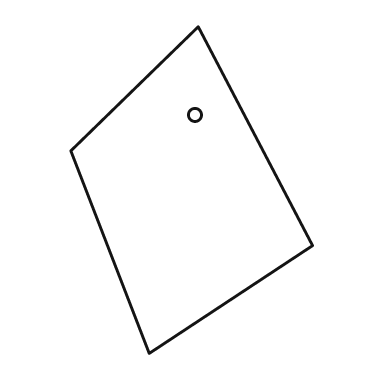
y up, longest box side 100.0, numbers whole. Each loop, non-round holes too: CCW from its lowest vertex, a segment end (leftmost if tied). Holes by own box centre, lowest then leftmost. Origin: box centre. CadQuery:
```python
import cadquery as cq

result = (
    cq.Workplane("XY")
    .moveTo(-13.0, -50.0)
    .lineTo(37.0, -17.0)
    .lineTo(2.0, 50.0)
    .lineTo(-37.0, 12.0)
    .close()
    .moveTo(1.0, 23.0)
    .circle(2.0)
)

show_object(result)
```